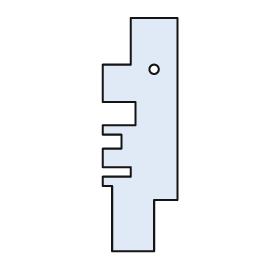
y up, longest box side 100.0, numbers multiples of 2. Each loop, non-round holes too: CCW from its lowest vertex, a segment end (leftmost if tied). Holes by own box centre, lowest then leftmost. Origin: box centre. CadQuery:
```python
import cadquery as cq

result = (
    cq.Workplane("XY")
    .moveTo(-12.0, -50.0)
    .lineTo(6.0, -50.0)
    .lineTo(6.0, -28.0)
    .lineTo(16.0, -28.0)
    .lineTo(16.0, 50.0)
    .lineTo(-4.0, 50.0)
    .lineTo(-4.0, 30.0)
    .lineTo(-16.0, 30.0)
    .lineTo(-16.0, 14.0)
    .lineTo(-2.0, 14.0)
    .lineTo(-2.0, 4.0)
    .lineTo(-16.0, 4.0)
    .lineTo(-16.0, 0.0)
    .lineTo(-8.0, 0.0)
    .lineTo(-8.0, -6.0)
    .lineTo(-16.0, -6.0)
    .lineTo(-16.0, -14.0)
    .lineTo(-4.0, -14.0)
    .lineTo(-4.0, -18.0)
    .lineTo(-16.0, -18.0)
    .lineTo(-16.0, -22.0)
    .lineTo(-12.0, -22.0)
    .close()
    .moveTo(6.0, 28.0)
    .circle(2.0)
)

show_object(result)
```